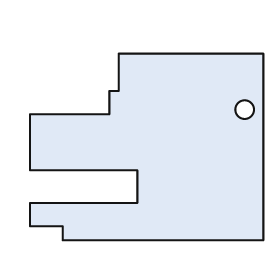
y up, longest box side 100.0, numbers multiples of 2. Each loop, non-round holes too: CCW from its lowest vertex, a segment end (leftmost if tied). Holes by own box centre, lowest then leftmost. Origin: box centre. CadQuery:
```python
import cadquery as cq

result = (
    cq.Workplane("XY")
    .moveTo(-36.0, -40.0)
    .lineTo(50.0, -40.0)
    .lineTo(50.0, 40.0)
    .lineTo(-12.0, 40.0)
    .lineTo(-12.0, 24.0)
    .lineTo(-16.0, 24.0)
    .lineTo(-16.0, 14.0)
    .lineTo(-50.0, 14.0)
    .lineTo(-50.0, -10.0)
    .lineTo(-4.0, -10.0)
    .lineTo(-4.0, -24.0)
    .lineTo(-50.0, -24.0)
    .lineTo(-50.0, -34.0)
    .lineTo(-36.0, -34.0)
    .close()
    .moveTo(42.0, 16.0)
    .circle(4.0)
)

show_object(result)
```